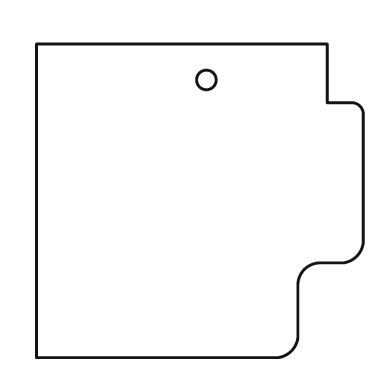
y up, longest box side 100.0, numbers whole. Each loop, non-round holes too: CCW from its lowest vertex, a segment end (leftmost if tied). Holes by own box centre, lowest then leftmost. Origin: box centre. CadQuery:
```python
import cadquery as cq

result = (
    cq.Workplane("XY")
    .moveTo(-50.0, -48.0)
    .lineTo(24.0, -48.0)
    .threePointArc((28.0, -46.0), (30.0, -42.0))
    .lineTo(30.0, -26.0)
    .threePointArc((32.0, -21.0), (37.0, -19.0))
    .lineTo(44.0, -19.0)
    .threePointArc((48.0, -17.0), (50.0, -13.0))
    .lineTo(50.0, 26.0)
    .threePointArc((49.0, 29.0), (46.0, 30.0))
    .lineTo(39.0, 30.0)
    .lineTo(39.0, 48.0)
    .lineTo(-50.0, 48.0)
    .close()
    .moveTo(2.0, 37.0)
    .circle(3.0)
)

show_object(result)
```